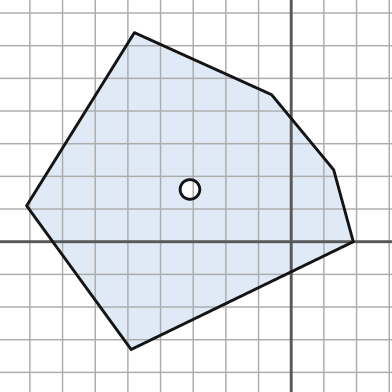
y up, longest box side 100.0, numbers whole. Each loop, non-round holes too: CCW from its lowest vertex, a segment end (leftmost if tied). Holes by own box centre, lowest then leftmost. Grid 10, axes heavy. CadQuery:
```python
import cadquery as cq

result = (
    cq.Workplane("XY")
    .moveTo(-49.0, -33.0)
    .lineTo(19.0, 0.0)
    .lineTo(13.0, 22.0)
    .lineTo(-6.0, 45.0)
    .lineTo(-48.0, 64.0)
    .lineTo(-81.0, 11.0)
    .close()
    .moveTo(-31.0, 16.0)
    .circle(3.0)
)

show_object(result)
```